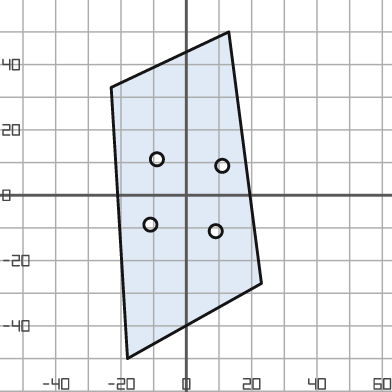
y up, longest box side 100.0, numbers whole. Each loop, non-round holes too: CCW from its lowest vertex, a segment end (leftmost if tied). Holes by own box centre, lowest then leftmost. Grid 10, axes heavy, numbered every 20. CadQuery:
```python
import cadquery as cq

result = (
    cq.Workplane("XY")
    .moveTo(-18.0, -50.0)
    .lineTo(23.0, -27.0)
    .lineTo(13.0, 50.0)
    .lineTo(-23.0, 33.0)
    .close()
    .moveTo(9.0, -11.0)
    .circle(2.0)
    .moveTo(-11.0, -9.0)
    .circle(2.0)
    .moveTo(11.0, 9.0)
    .circle(2.0)
    .moveTo(-9.0, 11.0)
    .circle(2.0)
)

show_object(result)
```